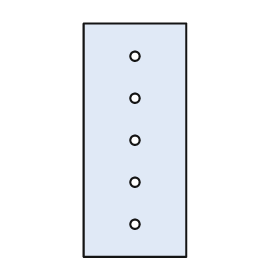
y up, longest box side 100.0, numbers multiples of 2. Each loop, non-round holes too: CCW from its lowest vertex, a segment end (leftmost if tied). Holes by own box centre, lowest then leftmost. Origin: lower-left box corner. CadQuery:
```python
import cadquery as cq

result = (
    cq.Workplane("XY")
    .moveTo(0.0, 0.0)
    .lineTo(44.0, 0.0)
    .lineTo(44.0, 100.0)
    .lineTo(0.0, 100.0)
    .close()
    .moveTo(22.0, 14.0)
    .circle(2.0)
    .moveTo(22.0, 32.0)
    .circle(2.0)
    .moveTo(22.0, 50.0)
    .circle(2.0)
    .moveTo(22.0, 68.0)
    .circle(2.0)
    .moveTo(22.0, 86.0)
    .circle(2.0)
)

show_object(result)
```